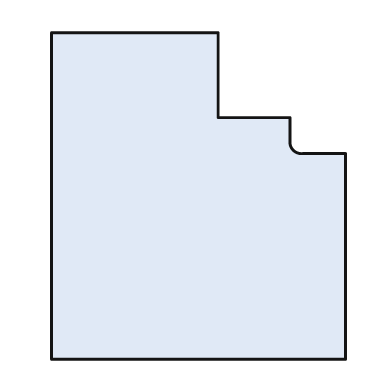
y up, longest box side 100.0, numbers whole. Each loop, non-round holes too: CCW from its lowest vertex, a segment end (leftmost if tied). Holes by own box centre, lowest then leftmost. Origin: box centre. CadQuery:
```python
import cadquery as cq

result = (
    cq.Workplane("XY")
    .moveTo(-45.0, -50.0)
    .lineTo(45.0, -50.0)
    .lineTo(45.0, 13.0)
    .lineTo(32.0, 13.0)
    .threePointArc((29.0, 14.0), (28.0, 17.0))
    .lineTo(28.0, 24.0)
    .lineTo(6.0, 24.0)
    .lineTo(6.0, 50.0)
    .lineTo(-45.0, 50.0)
    .close()
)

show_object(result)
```